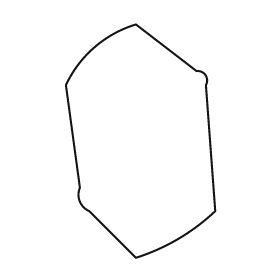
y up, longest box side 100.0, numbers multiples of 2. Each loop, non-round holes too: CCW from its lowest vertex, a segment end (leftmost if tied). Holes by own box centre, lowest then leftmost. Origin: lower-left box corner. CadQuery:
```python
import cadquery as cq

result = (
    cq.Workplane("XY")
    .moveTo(30.0, 0.0)
    .threePointArc((48.0, 8.0), (64.0, 20.0))
    .lineTo(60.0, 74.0)
    .threePointArc((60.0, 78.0), (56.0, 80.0))
    .lineTo(30.0, 100.0)
    .threePointArc((12.0, 90.0), (0.0, 74.0))
    .lineTo(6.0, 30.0)
    .threePointArc((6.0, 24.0), (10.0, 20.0))
    .close()
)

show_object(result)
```